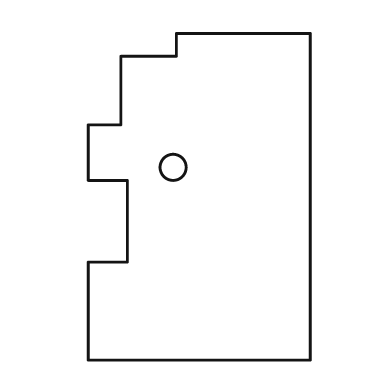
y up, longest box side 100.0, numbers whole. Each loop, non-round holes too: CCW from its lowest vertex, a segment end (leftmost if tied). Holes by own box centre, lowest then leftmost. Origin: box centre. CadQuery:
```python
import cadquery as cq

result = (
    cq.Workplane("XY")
    .moveTo(-34.0, -50.0)
    .lineTo(34.0, -50.0)
    .lineTo(34.0, 50.0)
    .lineTo(-7.0, 50.0)
    .lineTo(-7.0, 43.0)
    .lineTo(-24.0, 43.0)
    .lineTo(-24.0, 22.0)
    .lineTo(-34.0, 22.0)
    .lineTo(-34.0, 5.0)
    .lineTo(-22.0, 5.0)
    .lineTo(-22.0, -20.0)
    .lineTo(-34.0, -20.0)
    .close()
    .moveTo(-8.0, 9.0)
    .circle(4.0)
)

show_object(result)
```